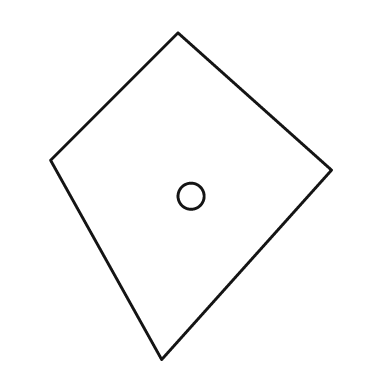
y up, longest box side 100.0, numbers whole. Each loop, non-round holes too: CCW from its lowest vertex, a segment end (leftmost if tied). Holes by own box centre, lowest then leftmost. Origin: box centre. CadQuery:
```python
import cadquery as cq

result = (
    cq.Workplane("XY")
    .moveTo(-9.0, -50.0)
    .lineTo(43.0, 8.0)
    .lineTo(-4.0, 50.0)
    .lineTo(-43.0, 11.0)
    .close()
    .moveTo(0.0, 0.0)
    .circle(4.0)
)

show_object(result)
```